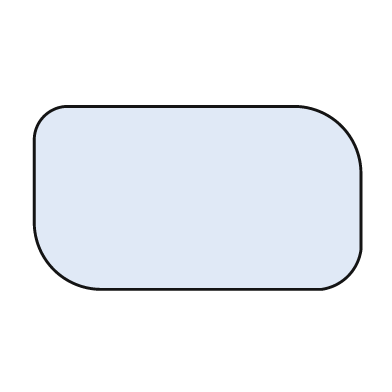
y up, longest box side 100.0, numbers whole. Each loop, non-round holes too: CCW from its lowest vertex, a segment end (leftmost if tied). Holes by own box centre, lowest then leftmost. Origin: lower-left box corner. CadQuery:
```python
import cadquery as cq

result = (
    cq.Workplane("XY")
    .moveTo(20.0, 0.0)
    .lineTo(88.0, 0.0)
    .threePointArc((96.0, 4.0), (100.0, 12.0))
    .lineTo(100.0, 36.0)
    .threePointArc((94.0, 50.0), (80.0, 56.0))
    .lineTo(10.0, 56.0)
    .threePointArc((3.0, 53.0), (0.0, 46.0))
    .lineTo(0.0, 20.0)
    .threePointArc((6.0, 6.0), (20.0, 0.0))
    .close()
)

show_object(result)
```